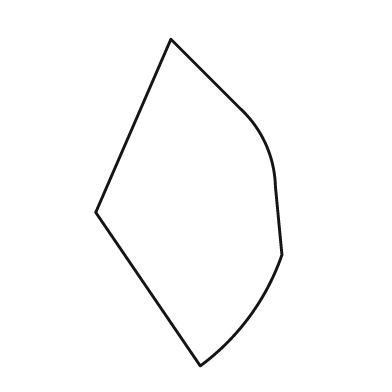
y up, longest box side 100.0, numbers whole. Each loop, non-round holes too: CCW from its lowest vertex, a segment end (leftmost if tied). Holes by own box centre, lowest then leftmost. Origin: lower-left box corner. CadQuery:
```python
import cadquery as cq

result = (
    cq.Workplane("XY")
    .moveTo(32.0, 0.0)
    .threePointArc((47.0, 15.0), (57.0, 34.0))
    .lineTo(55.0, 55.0)
    .threePointArc((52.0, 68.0), (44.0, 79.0))
    .lineTo(23.0, 100.0)
    .lineTo(0.0, 47.0)
    .close()
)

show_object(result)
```